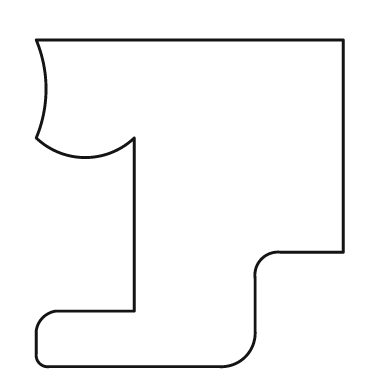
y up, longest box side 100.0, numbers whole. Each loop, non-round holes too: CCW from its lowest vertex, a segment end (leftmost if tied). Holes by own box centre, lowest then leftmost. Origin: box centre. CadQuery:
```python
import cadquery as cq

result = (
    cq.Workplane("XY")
    .moveTo(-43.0, -50.0)
    .lineTo(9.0, -50.0)
    .threePointArc((17.0, -47.0), (20.0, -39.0))
    .lineTo(20.0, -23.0)
    .threePointArc((22.0, -17.0), (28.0, -15.0))
    .lineTo(47.0, -15.0)
    .lineTo(47.0, 50.0)
    .lineTo(-47.0, 50.0)
    .threePointArc((-44.0, 35.0), (-47.0, 20.0))
    .threePointArc((-32.0, 14.0), (-17.0, 20.0))
    .lineTo(-17.0, -33.0)
    .lineTo(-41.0, -33.0)
    .threePointArc((-45.0, -35.0), (-47.0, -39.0))
    .lineTo(-47.0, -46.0)
    .threePointArc((-46.0, -49.0), (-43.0, -50.0))
    .close()
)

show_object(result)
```